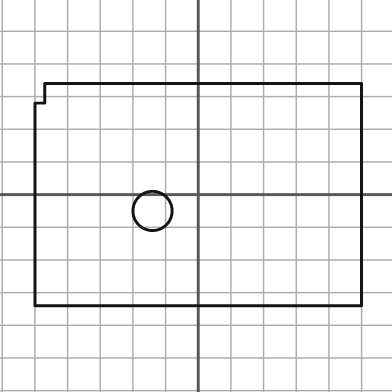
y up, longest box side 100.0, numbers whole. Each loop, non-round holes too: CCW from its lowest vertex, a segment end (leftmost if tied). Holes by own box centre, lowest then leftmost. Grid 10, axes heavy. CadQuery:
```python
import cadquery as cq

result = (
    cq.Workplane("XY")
    .moveTo(-50.0, -34.0)
    .lineTo(50.0, -34.0)
    .lineTo(50.0, 34.0)
    .lineTo(-47.0, 34.0)
    .lineTo(-47.0, 28.0)
    .lineTo(-50.0, 28.0)
    .close()
    .moveTo(-14.0, -5.0)
    .circle(6.0)
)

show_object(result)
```